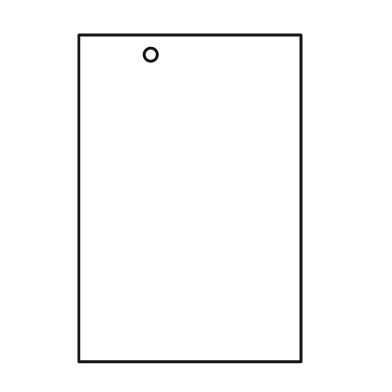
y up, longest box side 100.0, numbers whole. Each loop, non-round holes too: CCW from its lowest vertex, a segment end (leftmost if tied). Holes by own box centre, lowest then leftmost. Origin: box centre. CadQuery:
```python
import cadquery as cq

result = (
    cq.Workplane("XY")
    .moveTo(-34.0, -50.0)
    .lineTo(34.0, -50.0)
    .lineTo(34.0, 50.0)
    .lineTo(-34.0, 50.0)
    .close()
    .moveTo(-12.0, 44.0)
    .circle(2.0)
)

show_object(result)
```